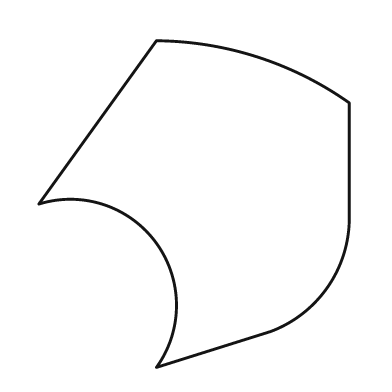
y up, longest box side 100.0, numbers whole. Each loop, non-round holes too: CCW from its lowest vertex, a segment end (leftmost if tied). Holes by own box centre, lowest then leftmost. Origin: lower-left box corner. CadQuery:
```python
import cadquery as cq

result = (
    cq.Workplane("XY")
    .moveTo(36.0, 0.0)
    .lineTo(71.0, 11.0)
    .threePointArc((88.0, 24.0), (95.0, 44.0))
    .lineTo(95.0, 81.0)
    .threePointArc((67.0, 95.0), (36.0, 100.0))
    .lineTo(0.0, 50.0)
    .threePointArc((36.0, 38.0), (36.0, 0.0))
    .close()
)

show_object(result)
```